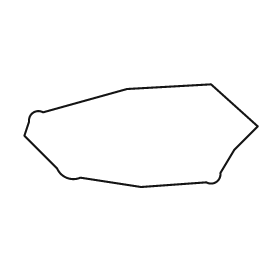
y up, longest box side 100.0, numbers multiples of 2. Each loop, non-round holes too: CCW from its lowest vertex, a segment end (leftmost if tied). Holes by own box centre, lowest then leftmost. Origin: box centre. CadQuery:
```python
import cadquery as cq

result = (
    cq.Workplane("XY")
    .moveTo(0.0, -22.0)
    .lineTo(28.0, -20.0)
    .threePointArc((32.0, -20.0), (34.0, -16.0))
    .lineTo(40.0, -6.0)
    .lineTo(50.0, 4.0)
    .lineTo(30.0, 22.0)
    .lineTo(-6.0, 20.0)
    .lineTo(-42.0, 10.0)
    .threePointArc((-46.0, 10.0), (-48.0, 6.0))
    .lineTo(-50.0, 0.0)
    .lineTo(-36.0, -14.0)
    .threePointArc((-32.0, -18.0), (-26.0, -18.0))
    .close()
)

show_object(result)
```